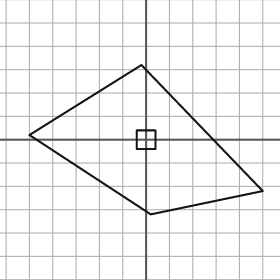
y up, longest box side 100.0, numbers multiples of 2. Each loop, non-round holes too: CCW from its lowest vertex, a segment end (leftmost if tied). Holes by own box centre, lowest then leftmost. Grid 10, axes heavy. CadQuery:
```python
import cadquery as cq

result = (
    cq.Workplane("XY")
    .moveTo(2.0, -32.0)
    .lineTo(50.0, -22.0)
    .lineTo(-2.0, 32.0)
    .lineTo(-50.0, 2.0)
    .close()
    .moveTo(-4.0, -4.0)
    .lineTo(4.0, -4.0)
    .lineTo(4.0, 4.0)
    .lineTo(-4.0, 4.0)
    .close()
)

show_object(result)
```